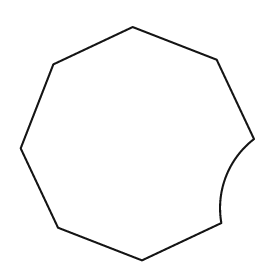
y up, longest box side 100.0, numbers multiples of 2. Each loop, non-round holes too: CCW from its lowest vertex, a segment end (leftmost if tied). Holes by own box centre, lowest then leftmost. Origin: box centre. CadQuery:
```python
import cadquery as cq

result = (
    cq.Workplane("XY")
    .moveTo(2.0, -50.0)
    .lineTo(36.0, -34.0)
    .threePointArc((38.0, -14.0), (50.0, 2.0))
    .lineTo(34.0, 36.0)
    .lineTo(-2.0, 50.0)
    .lineTo(-36.0, 34.0)
    .lineTo(-50.0, -2.0)
    .lineTo(-34.0, -36.0)
    .close()
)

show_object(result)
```